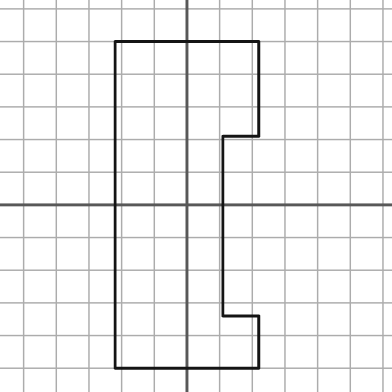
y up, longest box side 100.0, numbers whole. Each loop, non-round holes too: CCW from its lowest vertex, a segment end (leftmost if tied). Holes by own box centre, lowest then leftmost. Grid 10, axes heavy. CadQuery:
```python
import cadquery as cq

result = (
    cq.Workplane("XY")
    .moveTo(-22.0, -50.0)
    .lineTo(22.0, -50.0)
    .lineTo(22.0, -34.0)
    .lineTo(11.0, -34.0)
    .lineTo(11.0, 21.0)
    .lineTo(22.0, 21.0)
    .lineTo(22.0, 50.0)
    .lineTo(-22.0, 50.0)
    .close()
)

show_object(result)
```